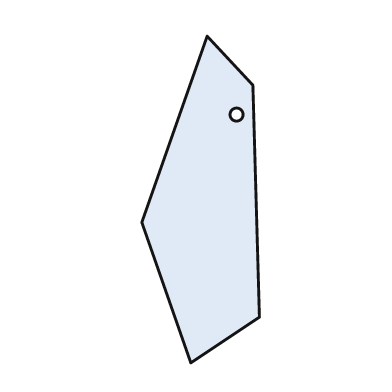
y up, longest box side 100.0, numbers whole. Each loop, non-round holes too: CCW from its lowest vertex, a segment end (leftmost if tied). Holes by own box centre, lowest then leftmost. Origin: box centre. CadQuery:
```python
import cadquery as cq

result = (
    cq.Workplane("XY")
    .moveTo(-3.0, -50.0)
    .lineTo(18.0, -36.0)
    .lineTo(16.0, 35.0)
    .lineTo(2.0, 50.0)
    .lineTo(-18.0, -7.0)
    .close()
    .moveTo(11.0, 26.0)
    .circle(2.0)
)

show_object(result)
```